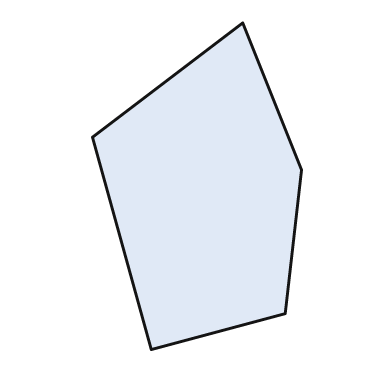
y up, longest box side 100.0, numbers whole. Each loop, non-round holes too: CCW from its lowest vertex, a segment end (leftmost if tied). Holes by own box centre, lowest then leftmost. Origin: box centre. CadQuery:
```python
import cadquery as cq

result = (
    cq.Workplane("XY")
    .moveTo(-14.0, -50.0)
    .lineTo(27.0, -39.0)
    .lineTo(32.0, 5.0)
    .lineTo(14.0, 50.0)
    .lineTo(-32.0, 15.0)
    .close()
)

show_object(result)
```